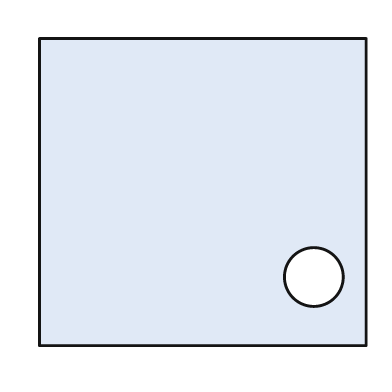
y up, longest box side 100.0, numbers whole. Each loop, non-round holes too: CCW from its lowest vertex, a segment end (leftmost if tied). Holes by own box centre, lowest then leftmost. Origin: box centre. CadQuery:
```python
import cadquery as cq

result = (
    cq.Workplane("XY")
    .moveTo(-50.0, -47.0)
    .lineTo(50.0, -47.0)
    .lineTo(50.0, 47.0)
    .lineTo(-50.0, 47.0)
    .close()
    .moveTo(34.0, -26.0)
    .circle(9.0)
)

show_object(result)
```